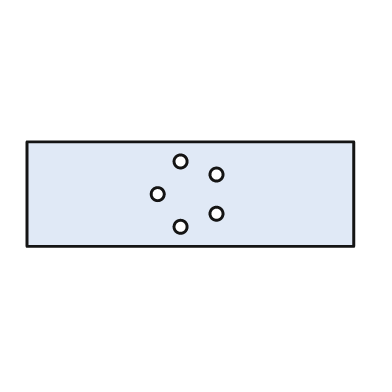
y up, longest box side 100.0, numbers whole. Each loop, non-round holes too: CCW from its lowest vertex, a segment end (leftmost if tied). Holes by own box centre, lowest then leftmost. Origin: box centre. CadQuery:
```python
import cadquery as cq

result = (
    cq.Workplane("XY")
    .moveTo(-50.0, -16.0)
    .lineTo(50.0, -16.0)
    .lineTo(50.0, 16.0)
    .lineTo(-50.0, 16.0)
    .close()
    .moveTo(-3.0, -10.0)
    .circle(2.0)
    .moveTo(8.0, -6.0)
    .circle(2.0)
    .moveTo(-10.0, 0.0)
    .circle(2.0)
    .moveTo(8.0, 6.0)
    .circle(2.0)
    .moveTo(-3.0, 10.0)
    .circle(2.0)
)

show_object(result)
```